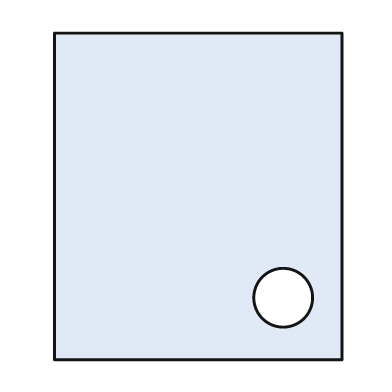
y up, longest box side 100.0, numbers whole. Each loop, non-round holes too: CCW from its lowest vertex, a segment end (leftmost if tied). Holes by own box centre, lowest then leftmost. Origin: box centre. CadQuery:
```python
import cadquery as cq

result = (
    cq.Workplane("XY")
    .moveTo(-44.0, -50.0)
    .lineTo(44.0, -50.0)
    .lineTo(44.0, 50.0)
    .lineTo(-44.0, 50.0)
    .close()
    .moveTo(26.0, -31.0)
    .circle(9.0)
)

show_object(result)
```